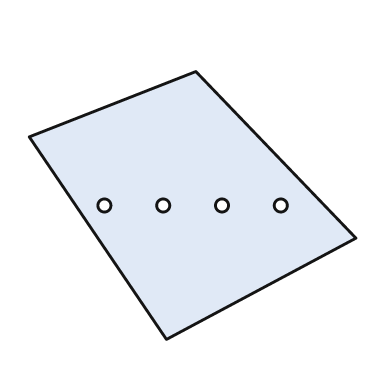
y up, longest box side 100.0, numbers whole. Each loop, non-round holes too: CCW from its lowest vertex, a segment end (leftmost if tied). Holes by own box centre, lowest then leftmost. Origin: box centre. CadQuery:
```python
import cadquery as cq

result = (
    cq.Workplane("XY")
    .moveTo(-8.0, -41.0)
    .lineTo(50.0, -10.0)
    .lineTo(1.0, 41.0)
    .lineTo(-50.0, 21.0)
    .close()
    .moveTo(-27.0, 0.0)
    .circle(2.0)
    .moveTo(-9.0, 0.0)
    .circle(2.0)
    .moveTo(9.0, 0.0)
    .circle(2.0)
    .moveTo(27.0, 0.0)
    .circle(2.0)
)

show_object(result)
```